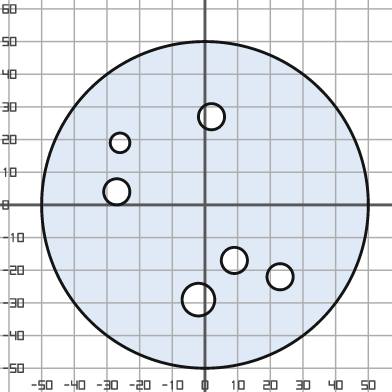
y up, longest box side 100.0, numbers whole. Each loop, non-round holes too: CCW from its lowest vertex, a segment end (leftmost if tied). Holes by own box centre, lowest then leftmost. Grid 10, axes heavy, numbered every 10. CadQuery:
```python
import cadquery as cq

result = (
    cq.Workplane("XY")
    .moveTo(0.0, 0.0)
    .circle(50.0)
    .moveTo(-2.0, -29.0)
    .circle(5.0)
    .moveTo(23.0, -22.0)
    .circle(4.0)
    .moveTo(9.0, -17.0)
    .circle(4.0)
    .moveTo(-27.0, 4.0)
    .circle(4.0)
    .moveTo(-26.0, 19.0)
    .circle(3.0)
    .moveTo(2.0, 27.0)
    .circle(4.0)
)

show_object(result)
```